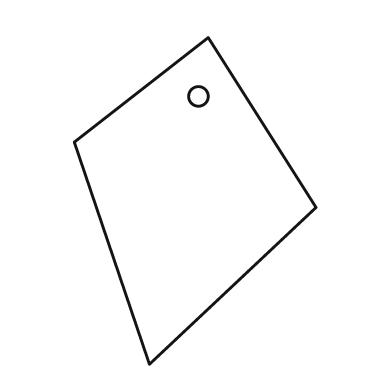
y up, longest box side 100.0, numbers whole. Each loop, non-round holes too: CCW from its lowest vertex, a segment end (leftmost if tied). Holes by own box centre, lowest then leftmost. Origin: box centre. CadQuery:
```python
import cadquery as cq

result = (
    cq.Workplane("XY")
    .moveTo(-14.0, -50.0)
    .lineTo(37.0, -2.0)
    .lineTo(4.0, 50.0)
    .lineTo(-37.0, 18.0)
    .close()
    .moveTo(1.0, 32.0)
    .circle(3.0)
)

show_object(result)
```